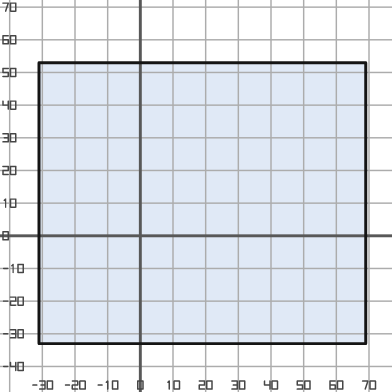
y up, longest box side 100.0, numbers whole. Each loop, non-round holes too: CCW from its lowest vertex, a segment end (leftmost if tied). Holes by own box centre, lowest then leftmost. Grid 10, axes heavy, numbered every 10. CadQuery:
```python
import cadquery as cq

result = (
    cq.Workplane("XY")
    .moveTo(-31.0, -33.0)
    .lineTo(69.0, -33.0)
    .lineTo(69.0, 53.0)
    .lineTo(-31.0, 53.0)
    .close()
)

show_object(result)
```